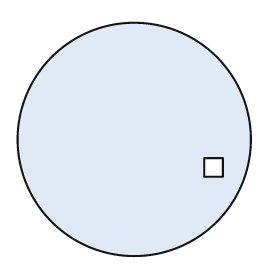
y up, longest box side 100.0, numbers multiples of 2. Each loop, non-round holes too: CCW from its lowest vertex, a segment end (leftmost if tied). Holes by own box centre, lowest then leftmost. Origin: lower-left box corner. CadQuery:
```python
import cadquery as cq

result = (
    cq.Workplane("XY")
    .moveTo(50.0, 50.0)
    .circle(50.0)
    .moveTo(80.0, 34.0)
    .lineTo(88.0, 34.0)
    .lineTo(88.0, 42.0)
    .lineTo(80.0, 42.0)
    .close()
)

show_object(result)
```